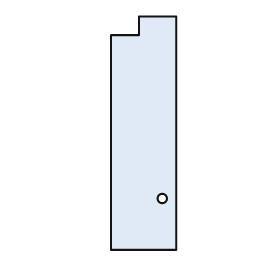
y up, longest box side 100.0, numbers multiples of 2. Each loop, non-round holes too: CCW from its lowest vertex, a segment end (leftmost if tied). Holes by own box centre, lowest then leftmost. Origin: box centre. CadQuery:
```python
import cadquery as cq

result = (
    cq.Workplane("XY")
    .moveTo(-14.0, -50.0)
    .lineTo(14.0, -50.0)
    .lineTo(14.0, 50.0)
    .lineTo(-2.0, 50.0)
    .lineTo(-2.0, 42.0)
    .lineTo(-14.0, 42.0)
    .close()
    .moveTo(8.0, -28.0)
    .circle(2.0)
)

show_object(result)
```